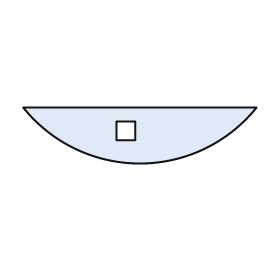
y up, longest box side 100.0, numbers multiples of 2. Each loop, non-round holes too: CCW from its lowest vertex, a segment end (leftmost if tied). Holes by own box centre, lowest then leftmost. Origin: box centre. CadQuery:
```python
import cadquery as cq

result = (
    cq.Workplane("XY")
    .moveTo(-50.0, 12.0)
    .threePointArc((0.0, -12.0), (50.0, 12.0))
    .close()
    .moveTo(-10.0, -2.0)
    .lineTo(-2.0, -2.0)
    .lineTo(-2.0, 6.0)
    .lineTo(-10.0, 6.0)
    .close()
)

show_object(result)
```